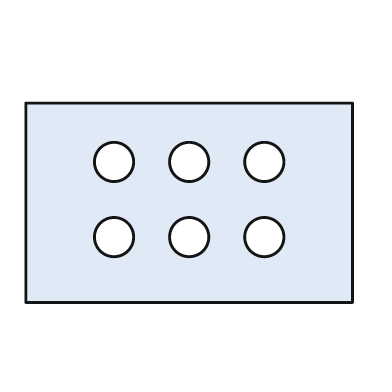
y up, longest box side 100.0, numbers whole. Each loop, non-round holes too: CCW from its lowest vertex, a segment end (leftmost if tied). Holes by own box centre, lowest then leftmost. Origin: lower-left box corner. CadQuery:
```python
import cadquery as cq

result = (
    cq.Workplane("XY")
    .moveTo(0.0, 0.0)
    .lineTo(100.0, 0.0)
    .lineTo(100.0, 61.0)
    .lineTo(0.0, 61.0)
    .close()
    .moveTo(27.0, 20.0)
    .circle(6.0)
    .moveTo(50.0, 20.0)
    .circle(6.0)
    .moveTo(73.0, 20.0)
    .circle(6.0)
    .moveTo(27.0, 43.0)
    .circle(6.0)
    .moveTo(50.0, 43.0)
    .circle(6.0)
    .moveTo(73.0, 43.0)
    .circle(6.0)
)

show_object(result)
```